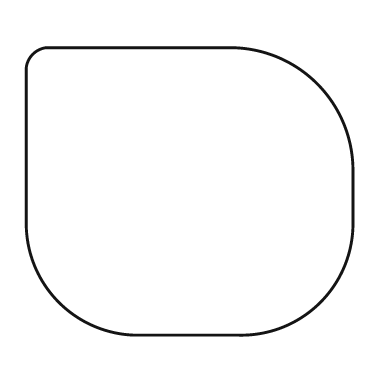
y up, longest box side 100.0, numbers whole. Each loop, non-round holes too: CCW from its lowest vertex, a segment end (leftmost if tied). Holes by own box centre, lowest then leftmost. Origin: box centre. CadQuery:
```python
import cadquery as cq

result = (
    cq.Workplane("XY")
    .moveTo(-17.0, -44.0)
    .lineTo(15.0, -44.0)
    .threePointArc((40.0, -34.0), (50.0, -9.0))
    .lineTo(50.0, 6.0)
    .threePointArc((39.0, 33.0), (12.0, 44.0))
    .lineTo(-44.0, 44.0)
    .threePointArc((-48.0, 42.0), (-50.0, 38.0))
    .lineTo(-50.0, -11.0)
    .threePointArc((-40.0, -34.0), (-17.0, -44.0))
    .close()
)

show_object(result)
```